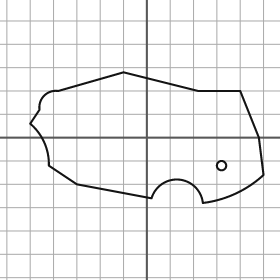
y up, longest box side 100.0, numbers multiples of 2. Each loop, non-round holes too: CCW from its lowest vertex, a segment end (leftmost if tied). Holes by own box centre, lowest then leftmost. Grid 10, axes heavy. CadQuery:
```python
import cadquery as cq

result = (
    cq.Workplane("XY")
    .moveTo(24.0, -28.0)
    .threePointArc((38.0, -24.0), (50.0, -16.0))
    .lineTo(48.0, 0.0)
    .lineTo(40.0, 20.0)
    .lineTo(22.0, 20.0)
    .lineTo(-10.0, 28.0)
    .lineTo(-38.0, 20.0)
    .threePointArc((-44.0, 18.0), (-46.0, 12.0))
    .lineTo(-50.0, 6.0)
    .threePointArc((-44.0, -2.0), (-42.0, -12.0))
    .lineTo(-30.0, -20.0)
    .lineTo(2.0, -26.0)
    .threePointArc((14.0, -18.0), (24.0, -28.0))
    .close()
    .moveTo(32.0, -12.0)
    .circle(2.0)
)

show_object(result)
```